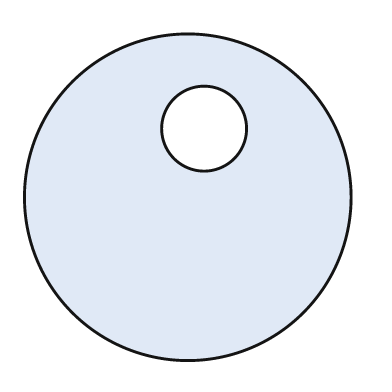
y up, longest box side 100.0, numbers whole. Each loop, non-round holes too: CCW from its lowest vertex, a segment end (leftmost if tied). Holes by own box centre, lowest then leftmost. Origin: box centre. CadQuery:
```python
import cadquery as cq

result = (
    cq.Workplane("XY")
    .moveTo(0.0, 0.0)
    .circle(50.0)
    .moveTo(5.0, 21.0)
    .circle(13.0)
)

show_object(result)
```